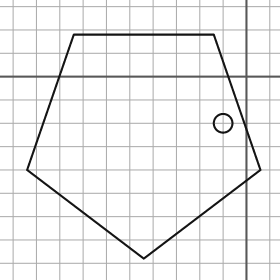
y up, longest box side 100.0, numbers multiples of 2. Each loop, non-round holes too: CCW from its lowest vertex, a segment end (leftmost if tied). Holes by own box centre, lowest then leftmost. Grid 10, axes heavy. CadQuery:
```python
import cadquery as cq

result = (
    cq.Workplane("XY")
    .moveTo(-44.0, -78.0)
    .lineTo(6.0, -40.0)
    .lineTo(-14.0, 18.0)
    .lineTo(-74.0, 18.0)
    .lineTo(-94.0, -40.0)
    .close()
    .moveTo(-10.0, -20.0)
    .circle(4.0)
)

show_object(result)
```